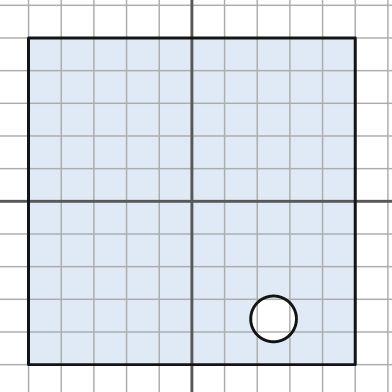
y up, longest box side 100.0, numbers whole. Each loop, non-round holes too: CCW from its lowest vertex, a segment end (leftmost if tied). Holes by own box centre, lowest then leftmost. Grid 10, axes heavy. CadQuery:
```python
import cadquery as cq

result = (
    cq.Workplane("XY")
    .moveTo(-50.0, -50.0)
    .lineTo(50.0, -50.0)
    .lineTo(50.0, 50.0)
    .lineTo(-50.0, 50.0)
    .close()
    .moveTo(25.0, -36.0)
    .circle(7.0)
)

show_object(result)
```